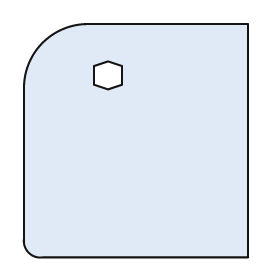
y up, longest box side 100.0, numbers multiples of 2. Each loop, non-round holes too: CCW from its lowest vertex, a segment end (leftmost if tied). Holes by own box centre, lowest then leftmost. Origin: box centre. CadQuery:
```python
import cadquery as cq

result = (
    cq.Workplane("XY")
    .moveTo(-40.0, -50.0)
    .lineTo(48.0, -50.0)
    .lineTo(48.0, 50.0)
    .lineTo(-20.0, 50.0)
    .threePointArc((-40.0, 42.0), (-48.0, 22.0))
    .lineTo(-48.0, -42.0)
    .threePointArc((-46.0, -48.0), (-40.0, -50.0))
    .close()
    .moveTo(-12.0, 22.0)
    .lineTo(-6.0, 24.0)
    .lineTo(-6.0, 32.0)
    .lineTo(-12.0, 34.0)
    .lineTo(-18.0, 32.0)
    .lineTo(-18.0, 24.0)
    .close()
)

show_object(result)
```